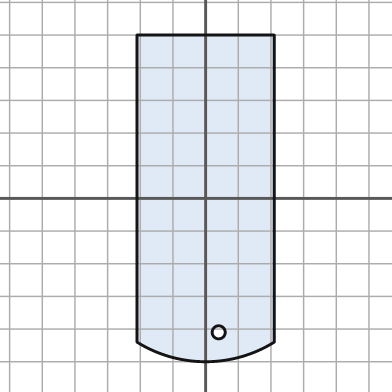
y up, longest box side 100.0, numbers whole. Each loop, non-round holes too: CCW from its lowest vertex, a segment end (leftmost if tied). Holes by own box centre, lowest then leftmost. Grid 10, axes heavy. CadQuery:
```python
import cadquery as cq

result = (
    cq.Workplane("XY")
    .moveTo(-21.0, -44.0)
    .threePointArc((0.0, -50.0), (21.0, -44.0))
    .lineTo(21.0, 50.0)
    .lineTo(-21.0, 50.0)
    .close()
    .moveTo(4.0, -41.0)
    .circle(2.0)
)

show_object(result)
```